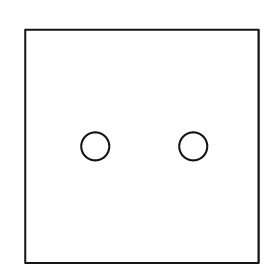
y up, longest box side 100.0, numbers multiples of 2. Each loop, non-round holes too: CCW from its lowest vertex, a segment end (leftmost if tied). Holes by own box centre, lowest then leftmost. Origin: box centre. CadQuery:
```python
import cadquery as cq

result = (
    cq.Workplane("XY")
    .moveTo(-50.0, -50.0)
    .lineTo(50.0, -50.0)
    .lineTo(50.0, 50.0)
    .lineTo(-50.0, 50.0)
    .close()
    .moveTo(-20.0, 0.0)
    .circle(6.0)
    .moveTo(22.0, 0.0)
    .circle(6.0)
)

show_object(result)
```